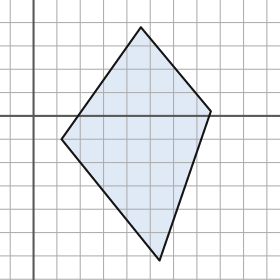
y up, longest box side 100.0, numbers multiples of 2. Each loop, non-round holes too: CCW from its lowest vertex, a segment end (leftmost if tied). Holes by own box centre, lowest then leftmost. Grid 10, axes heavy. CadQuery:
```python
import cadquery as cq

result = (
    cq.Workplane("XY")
    .moveTo(54.0, -62.0)
    .lineTo(76.0, 2.0)
    .lineTo(46.0, 38.0)
    .lineTo(12.0, -10.0)
    .close()
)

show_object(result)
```